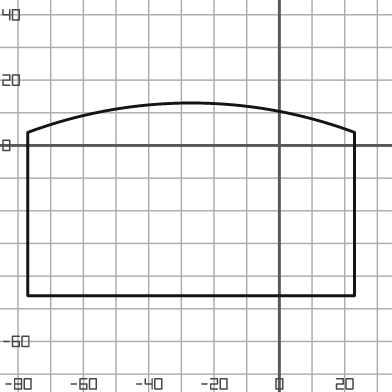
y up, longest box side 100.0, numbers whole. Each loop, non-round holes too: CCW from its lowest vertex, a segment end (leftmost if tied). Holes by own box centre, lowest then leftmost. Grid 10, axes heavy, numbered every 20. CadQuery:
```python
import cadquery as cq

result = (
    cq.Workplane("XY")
    .moveTo(-77.0, -46.0)
    .lineTo(23.0, -46.0)
    .lineTo(23.0, 4.0)
    .threePointArc((-27.0, 13.0), (-77.0, 4.0))
    .close()
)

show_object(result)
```